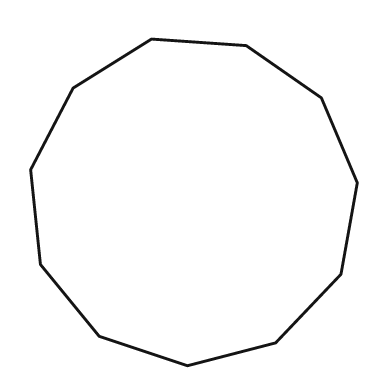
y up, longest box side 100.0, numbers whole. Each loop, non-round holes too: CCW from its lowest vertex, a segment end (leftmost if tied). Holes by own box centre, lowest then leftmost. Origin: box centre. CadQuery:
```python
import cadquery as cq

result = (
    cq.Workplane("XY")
    .moveTo(-2.0, -50.0)
    .lineTo(25.0, -43.0)
    .lineTo(45.0, -22.0)
    .lineTo(50.0, 6.0)
    .lineTo(39.0, 32.0)
    .lineTo(16.0, 48.0)
    .lineTo(-13.0, 50.0)
    .lineTo(-37.0, 35.0)
    .lineTo(-50.0, 10.0)
    .lineTo(-47.0, -19.0)
    .lineTo(-29.0, -41.0)
    .close()
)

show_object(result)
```